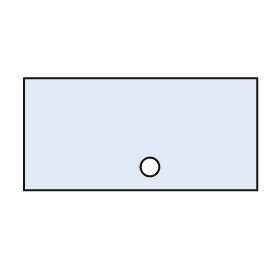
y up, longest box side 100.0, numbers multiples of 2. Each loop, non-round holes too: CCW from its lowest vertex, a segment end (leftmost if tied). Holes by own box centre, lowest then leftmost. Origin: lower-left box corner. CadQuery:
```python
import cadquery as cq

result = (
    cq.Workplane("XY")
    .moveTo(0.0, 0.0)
    .lineTo(100.0, 0.0)
    .lineTo(100.0, 48.0)
    .lineTo(0.0, 48.0)
    .close()
    .moveTo(54.0, 10.0)
    .circle(4.0)
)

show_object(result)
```